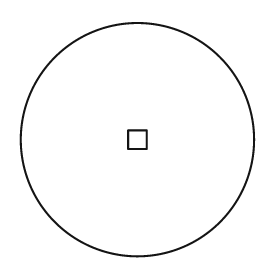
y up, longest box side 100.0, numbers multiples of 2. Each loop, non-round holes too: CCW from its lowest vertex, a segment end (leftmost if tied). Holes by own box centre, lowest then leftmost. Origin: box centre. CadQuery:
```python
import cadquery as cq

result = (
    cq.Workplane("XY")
    .moveTo(0.0, 0.0)
    .circle(50.0)
    .moveTo(-4.0, -4.0)
    .lineTo(4.0, -4.0)
    .lineTo(4.0, 4.0)
    .lineTo(-4.0, 4.0)
    .close()
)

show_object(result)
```